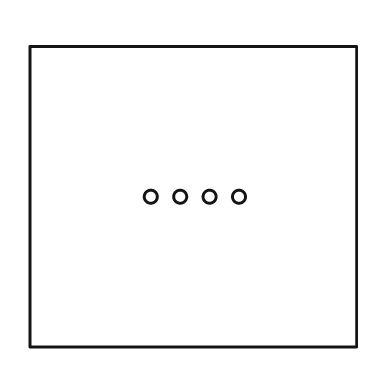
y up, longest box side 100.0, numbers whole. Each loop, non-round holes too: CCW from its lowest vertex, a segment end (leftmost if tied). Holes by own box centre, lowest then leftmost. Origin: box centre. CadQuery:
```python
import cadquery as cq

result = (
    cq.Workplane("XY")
    .moveTo(-50.0, -46.0)
    .lineTo(50.0, -46.0)
    .lineTo(50.0, 46.0)
    .lineTo(-50.0, 46.0)
    .close()
    .moveTo(-13.0, 0.0)
    .circle(2.0)
    .moveTo(-4.0, 0.0)
    .circle(2.0)
    .moveTo(5.0, 0.0)
    .circle(2.0)
    .moveTo(14.0, 0.0)
    .circle(2.0)
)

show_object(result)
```